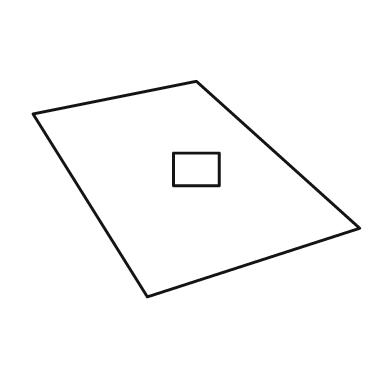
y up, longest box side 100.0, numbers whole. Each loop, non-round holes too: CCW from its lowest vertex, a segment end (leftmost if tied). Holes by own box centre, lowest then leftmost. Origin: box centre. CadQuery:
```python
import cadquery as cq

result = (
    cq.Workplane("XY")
    .moveTo(-15.0, -33.0)
    .lineTo(50.0, -12.0)
    .lineTo(0.0, 33.0)
    .lineTo(-50.0, 23.0)
    .close()
    .moveTo(-7.0, 1.0)
    .lineTo(7.0, 1.0)
    .lineTo(7.0, 11.0)
    .lineTo(-7.0, 11.0)
    .close()
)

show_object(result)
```